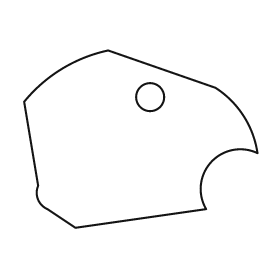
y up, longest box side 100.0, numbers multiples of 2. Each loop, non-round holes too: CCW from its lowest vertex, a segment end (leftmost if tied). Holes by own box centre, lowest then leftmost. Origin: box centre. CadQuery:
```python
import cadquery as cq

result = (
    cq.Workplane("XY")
    .moveTo(-28.0, -38.0)
    .lineTo(28.0, -30.0)
    .threePointArc((30.0, -10.0), (50.0, -6.0))
    .threePointArc((44.0, 10.0), (32.0, 22.0))
    .lineTo(-14.0, 38.0)
    .threePointArc((-34.0, 30.0), (-50.0, 16.0))
    .lineTo(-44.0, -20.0)
    .threePointArc((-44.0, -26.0), (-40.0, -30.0))
    .close()
    .moveTo(4.0, 18.0)
    .circle(6.0)
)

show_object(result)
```